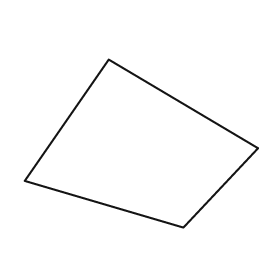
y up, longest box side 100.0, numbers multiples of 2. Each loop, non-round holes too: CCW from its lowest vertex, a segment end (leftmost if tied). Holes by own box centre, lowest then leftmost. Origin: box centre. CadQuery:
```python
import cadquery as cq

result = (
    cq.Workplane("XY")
    .moveTo(18.0, -36.0)
    .lineTo(50.0, -2.0)
    .lineTo(-14.0, 36.0)
    .lineTo(-50.0, -16.0)
    .close()
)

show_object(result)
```